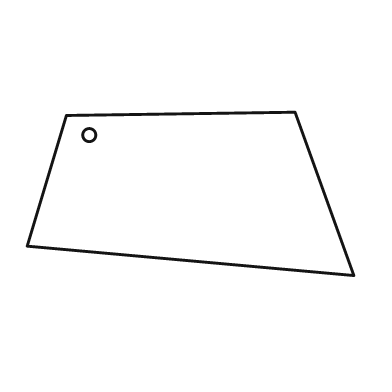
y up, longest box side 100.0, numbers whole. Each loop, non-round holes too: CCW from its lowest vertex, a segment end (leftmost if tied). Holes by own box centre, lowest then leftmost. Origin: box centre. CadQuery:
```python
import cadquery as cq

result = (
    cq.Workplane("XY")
    .moveTo(50.0, -25.0)
    .lineTo(32.0, 25.0)
    .lineTo(-38.0, 24.0)
    .lineTo(-50.0, -16.0)
    .close()
    .moveTo(-31.0, 18.0)
    .circle(2.0)
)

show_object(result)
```